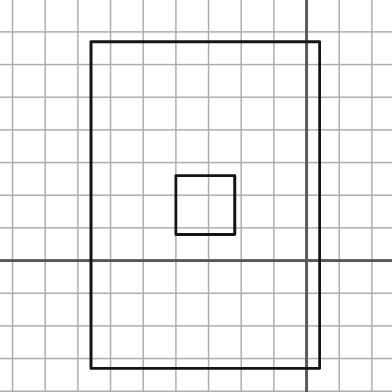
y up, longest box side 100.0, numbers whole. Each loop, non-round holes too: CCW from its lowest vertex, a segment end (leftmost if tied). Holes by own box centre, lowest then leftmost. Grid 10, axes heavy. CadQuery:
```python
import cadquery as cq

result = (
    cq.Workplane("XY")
    .moveTo(-66.0, -33.0)
    .lineTo(4.0, -33.0)
    .lineTo(4.0, 67.0)
    .lineTo(-66.0, 67.0)
    .close()
    .moveTo(-40.0, 8.0)
    .lineTo(-22.0, 8.0)
    .lineTo(-22.0, 26.0)
    .lineTo(-40.0, 26.0)
    .close()
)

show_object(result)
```